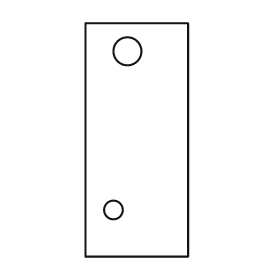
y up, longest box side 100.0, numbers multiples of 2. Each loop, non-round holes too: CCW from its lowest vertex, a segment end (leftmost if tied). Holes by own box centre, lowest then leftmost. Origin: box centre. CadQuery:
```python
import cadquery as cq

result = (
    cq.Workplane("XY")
    .moveTo(-22.0, -50.0)
    .lineTo(22.0, -50.0)
    .lineTo(22.0, 50.0)
    .lineTo(-22.0, 50.0)
    .close()
    .moveTo(-10.0, -30.0)
    .circle(4.0)
    .moveTo(-4.0, 38.0)
    .circle(6.0)
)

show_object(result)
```